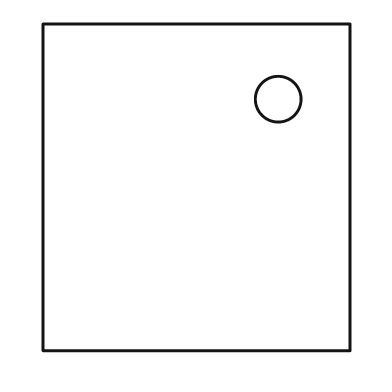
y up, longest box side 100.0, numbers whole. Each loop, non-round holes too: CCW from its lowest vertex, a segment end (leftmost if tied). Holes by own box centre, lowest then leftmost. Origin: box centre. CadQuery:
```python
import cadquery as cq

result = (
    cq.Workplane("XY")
    .moveTo(-47.0, -50.0)
    .lineTo(47.0, -50.0)
    .lineTo(47.0, 50.0)
    .lineTo(-47.0, 50.0)
    .close()
    .moveTo(25.0, 27.0)
    .circle(7.0)
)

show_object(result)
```